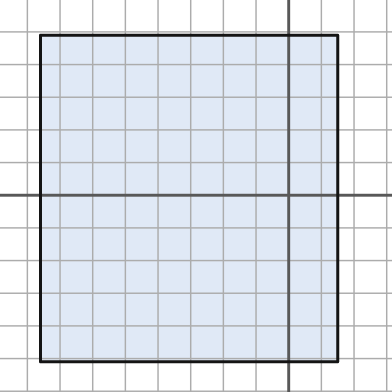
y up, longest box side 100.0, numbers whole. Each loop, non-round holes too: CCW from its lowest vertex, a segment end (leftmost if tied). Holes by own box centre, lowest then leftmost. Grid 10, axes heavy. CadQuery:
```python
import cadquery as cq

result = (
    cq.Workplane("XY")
    .moveTo(-76.0, -51.0)
    .lineTo(15.0, -51.0)
    .lineTo(15.0, 49.0)
    .lineTo(-76.0, 49.0)
    .close()
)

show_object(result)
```